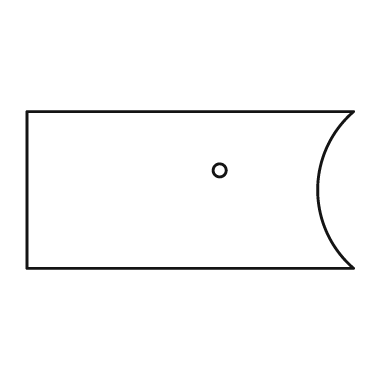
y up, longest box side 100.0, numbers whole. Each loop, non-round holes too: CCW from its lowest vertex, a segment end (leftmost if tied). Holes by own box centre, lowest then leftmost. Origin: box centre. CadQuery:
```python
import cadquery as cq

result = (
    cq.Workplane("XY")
    .moveTo(-50.0, -24.0)
    .lineTo(50.0, -24.0)
    .threePointArc((39.0, 0.0), (50.0, 24.0))
    .lineTo(-50.0, 24.0)
    .close()
    .moveTo(9.0, 6.0)
    .circle(2.0)
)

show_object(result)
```